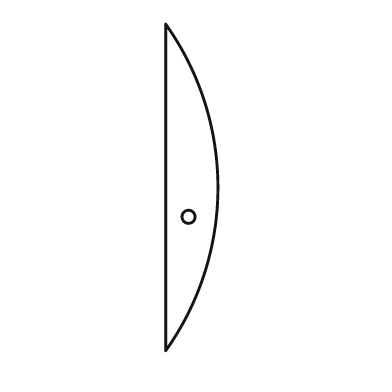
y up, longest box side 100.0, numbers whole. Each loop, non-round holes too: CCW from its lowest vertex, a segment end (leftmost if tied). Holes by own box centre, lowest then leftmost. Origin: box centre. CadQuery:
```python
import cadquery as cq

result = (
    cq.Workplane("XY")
    .moveTo(-8.0, -50.0)
    .threePointArc((8.0, 0.0), (-8.0, 50.0))
    .close()
    .moveTo(-1.0, -9.0)
    .circle(2.0)
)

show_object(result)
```